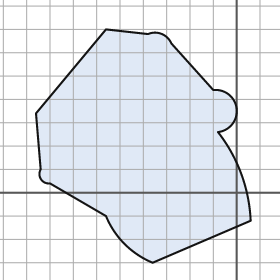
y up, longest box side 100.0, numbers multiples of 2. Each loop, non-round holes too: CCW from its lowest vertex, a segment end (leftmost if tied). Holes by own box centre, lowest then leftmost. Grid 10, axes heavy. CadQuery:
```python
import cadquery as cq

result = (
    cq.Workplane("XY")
    .moveTo(-36.0, -30.0)
    .lineTo(6.0, -12.0)
    .threePointArc((2.0, 8.0), (-8.0, 26.0))
    .threePointArc((0.0, 36.0), (-10.0, 44.0))
    .lineTo(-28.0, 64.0)
    .threePointArc((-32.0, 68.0), (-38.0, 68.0))
    .lineTo(-56.0, 70.0)
    .lineTo(-86.0, 34.0)
    .lineTo(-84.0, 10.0)
    .threePointArc((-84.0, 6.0), (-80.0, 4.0))
    .lineTo(-56.0, -10.0)
    .threePointArc((-48.0, -22.0), (-36.0, -30.0))
    .close()
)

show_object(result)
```